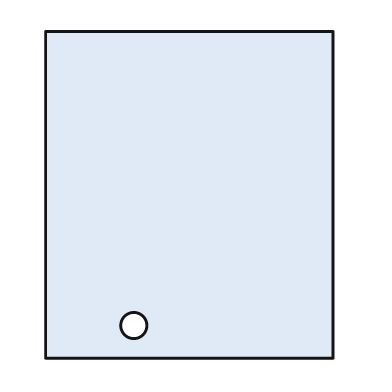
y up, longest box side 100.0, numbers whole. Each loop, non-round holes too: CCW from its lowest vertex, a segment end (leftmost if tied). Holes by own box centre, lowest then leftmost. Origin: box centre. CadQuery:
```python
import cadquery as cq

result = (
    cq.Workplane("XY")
    .moveTo(-44.0, -50.0)
    .lineTo(44.0, -50.0)
    .lineTo(44.0, 50.0)
    .lineTo(-44.0, 50.0)
    .close()
    .moveTo(-17.0, -40.0)
    .circle(4.0)
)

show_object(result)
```